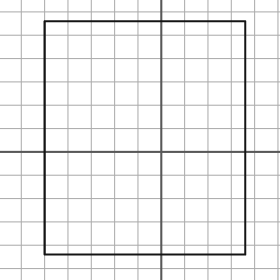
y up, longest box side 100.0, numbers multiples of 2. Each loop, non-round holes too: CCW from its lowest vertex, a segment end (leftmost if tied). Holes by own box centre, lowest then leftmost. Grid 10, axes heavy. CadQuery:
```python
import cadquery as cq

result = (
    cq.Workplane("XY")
    .moveTo(-50.0, -44.0)
    .lineTo(36.0, -44.0)
    .lineTo(36.0, 56.0)
    .lineTo(-50.0, 56.0)
    .close()
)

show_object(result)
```